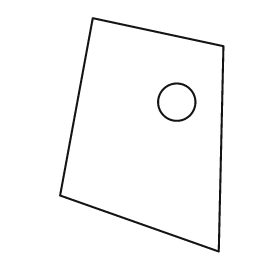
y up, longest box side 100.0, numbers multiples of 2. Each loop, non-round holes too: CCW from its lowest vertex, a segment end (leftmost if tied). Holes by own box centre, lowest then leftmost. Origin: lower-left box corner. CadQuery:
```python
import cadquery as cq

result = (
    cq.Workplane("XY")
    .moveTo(68.0, 0.0)
    .lineTo(70.0, 88.0)
    .lineTo(14.0, 100.0)
    .lineTo(0.0, 24.0)
    .close()
    .moveTo(50.0, 64.0)
    .circle(8.0)
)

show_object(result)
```